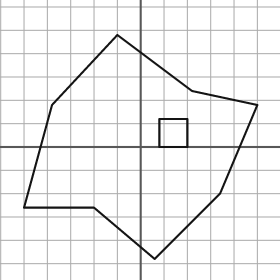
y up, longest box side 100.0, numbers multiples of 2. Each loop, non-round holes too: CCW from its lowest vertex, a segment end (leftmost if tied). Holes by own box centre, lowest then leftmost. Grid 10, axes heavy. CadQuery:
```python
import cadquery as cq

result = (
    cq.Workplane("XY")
    .moveTo(6.0, -48.0)
    .lineTo(34.0, -20.0)
    .lineTo(50.0, 18.0)
    .lineTo(22.0, 24.0)
    .lineTo(-10.0, 48.0)
    .lineTo(-38.0, 18.0)
    .lineTo(-50.0, -26.0)
    .lineTo(-20.0, -26.0)
    .close()
    .moveTo(8.0, 0.0)
    .lineTo(20.0, 0.0)
    .lineTo(20.0, 12.0)
    .lineTo(8.0, 12.0)
    .close()
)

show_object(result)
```